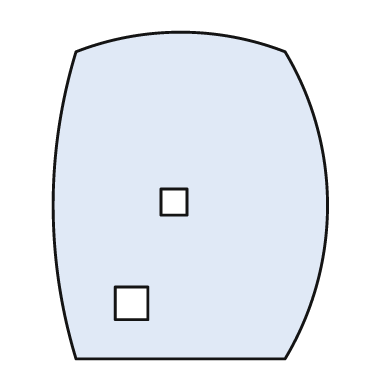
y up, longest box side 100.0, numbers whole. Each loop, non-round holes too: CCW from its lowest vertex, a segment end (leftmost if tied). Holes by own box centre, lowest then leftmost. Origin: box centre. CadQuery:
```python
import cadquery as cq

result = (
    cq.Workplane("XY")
    .moveTo(-35.0, -50.0)
    .lineTo(29.0, -50.0)
    .threePointArc((42.0, -3.0), (29.0, 44.0))
    .threePointArc((-3.0, 50.0), (-35.0, 44.0))
    .threePointArc((-42.0, -3.0), (-35.0, -50.0))
    .close()
    .moveTo(-23.0, -38.0)
    .lineTo(-13.0, -38.0)
    .lineTo(-13.0, -28.0)
    .lineTo(-23.0, -28.0)
    .close()
    .moveTo(-9.0, -6.0)
    .lineTo(-1.0, -6.0)
    .lineTo(-1.0, 2.0)
    .lineTo(-9.0, 2.0)
    .close()
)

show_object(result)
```